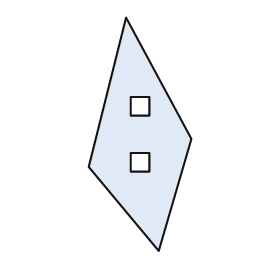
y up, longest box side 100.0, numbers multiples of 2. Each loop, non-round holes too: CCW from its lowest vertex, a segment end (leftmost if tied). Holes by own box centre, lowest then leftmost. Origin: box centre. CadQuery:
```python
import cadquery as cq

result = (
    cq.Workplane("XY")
    .moveTo(8.0, -50.0)
    .lineTo(22.0, -2.0)
    .lineTo(-6.0, 50.0)
    .lineTo(-22.0, -14.0)
    .close()
    .moveTo(-4.0, -16.0)
    .lineTo(4.0, -16.0)
    .lineTo(4.0, -8.0)
    .lineTo(-4.0, -8.0)
    .close()
    .moveTo(-4.0, 8.0)
    .lineTo(4.0, 8.0)
    .lineTo(4.0, 16.0)
    .lineTo(-4.0, 16.0)
    .close()
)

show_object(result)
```